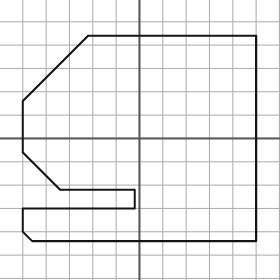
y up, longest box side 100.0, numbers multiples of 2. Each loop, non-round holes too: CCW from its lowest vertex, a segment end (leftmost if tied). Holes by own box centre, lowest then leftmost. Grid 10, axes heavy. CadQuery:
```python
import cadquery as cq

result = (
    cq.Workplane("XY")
    .moveTo(-46.0, -44.0)
    .lineTo(50.0, -44.0)
    .lineTo(50.0, 44.0)
    .lineTo(-22.0, 44.0)
    .lineTo(-50.0, 16.0)
    .lineTo(-50.0, -6.0)
    .lineTo(-34.0, -22.0)
    .lineTo(-2.0, -22.0)
    .lineTo(-2.0, -30.0)
    .lineTo(-50.0, -30.0)
    .lineTo(-50.0, -40.0)
    .close()
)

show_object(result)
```